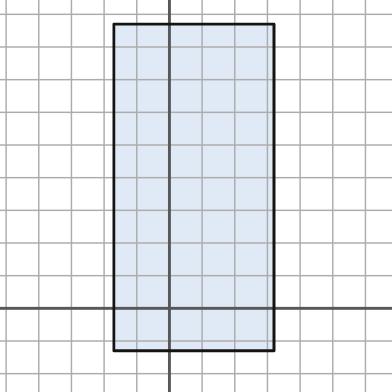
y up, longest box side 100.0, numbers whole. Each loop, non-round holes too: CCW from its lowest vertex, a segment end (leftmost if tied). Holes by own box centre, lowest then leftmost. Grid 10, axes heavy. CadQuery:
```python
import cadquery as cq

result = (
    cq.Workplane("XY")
    .moveTo(-17.0, -13.0)
    .lineTo(32.0, -13.0)
    .lineTo(32.0, 87.0)
    .lineTo(-17.0, 87.0)
    .close()
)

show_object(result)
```